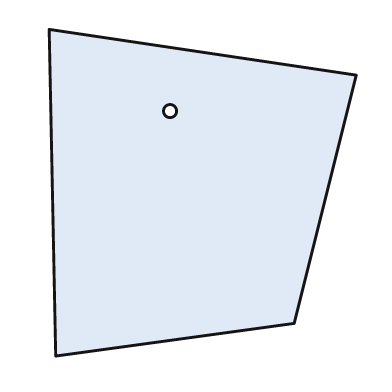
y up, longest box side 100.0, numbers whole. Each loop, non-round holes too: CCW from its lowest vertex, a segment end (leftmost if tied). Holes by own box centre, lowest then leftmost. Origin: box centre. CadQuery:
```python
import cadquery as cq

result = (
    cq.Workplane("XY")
    .moveTo(-45.0, -50.0)
    .lineTo(28.0, -40.0)
    .lineTo(47.0, 36.0)
    .lineTo(-47.0, 50.0)
    .close()
    .moveTo(-10.0, 25.0)
    .circle(2.0)
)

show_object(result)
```